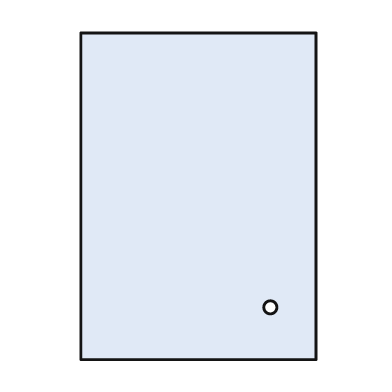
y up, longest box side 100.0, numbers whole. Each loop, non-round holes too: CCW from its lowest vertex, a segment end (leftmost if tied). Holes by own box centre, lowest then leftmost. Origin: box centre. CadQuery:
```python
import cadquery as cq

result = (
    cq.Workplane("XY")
    .moveTo(-36.0, -50.0)
    .lineTo(36.0, -50.0)
    .lineTo(36.0, 50.0)
    .lineTo(-36.0, 50.0)
    .close()
    .moveTo(22.0, -34.0)
    .circle(2.0)
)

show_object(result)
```